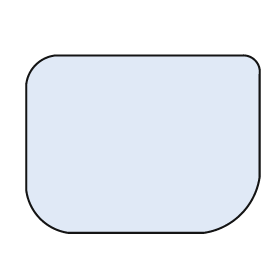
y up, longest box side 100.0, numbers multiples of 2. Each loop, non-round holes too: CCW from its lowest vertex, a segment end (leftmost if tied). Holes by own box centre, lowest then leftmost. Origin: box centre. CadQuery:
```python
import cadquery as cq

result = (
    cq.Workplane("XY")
    .moveTo(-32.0, -38.0)
    .lineTo(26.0, -38.0)
    .threePointArc((42.0, -30.0), (50.0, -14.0))
    .lineTo(50.0, 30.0)
    .threePointArc((48.0, 36.0), (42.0, 38.0))
    .lineTo(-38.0, 38.0)
    .threePointArc((-46.0, 34.0), (-50.0, 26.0))
    .lineTo(-50.0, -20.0)
    .threePointArc((-44.0, -32.0), (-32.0, -38.0))
    .close()
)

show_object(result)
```